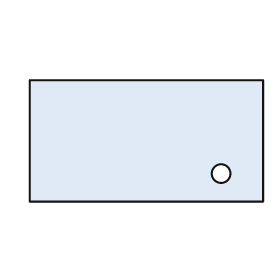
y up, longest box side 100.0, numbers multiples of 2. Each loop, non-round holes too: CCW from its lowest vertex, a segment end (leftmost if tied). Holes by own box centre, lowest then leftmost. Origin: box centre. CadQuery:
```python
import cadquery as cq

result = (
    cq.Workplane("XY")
    .moveTo(-50.0, -26.0)
    .lineTo(50.0, -26.0)
    .lineTo(50.0, 26.0)
    .lineTo(-50.0, 26.0)
    .close()
    .moveTo(32.0, -14.0)
    .circle(4.0)
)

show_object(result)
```